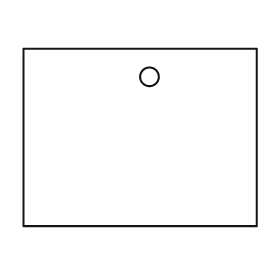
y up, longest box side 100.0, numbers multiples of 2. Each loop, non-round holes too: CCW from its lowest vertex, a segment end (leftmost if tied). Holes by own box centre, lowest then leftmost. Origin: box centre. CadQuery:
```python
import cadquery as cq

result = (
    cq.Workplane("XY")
    .moveTo(-50.0, -38.0)
    .lineTo(50.0, -38.0)
    .lineTo(50.0, 38.0)
    .lineTo(-50.0, 38.0)
    .close()
    .moveTo(4.0, 26.0)
    .circle(4.0)
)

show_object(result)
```